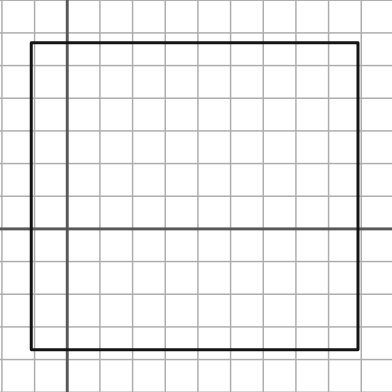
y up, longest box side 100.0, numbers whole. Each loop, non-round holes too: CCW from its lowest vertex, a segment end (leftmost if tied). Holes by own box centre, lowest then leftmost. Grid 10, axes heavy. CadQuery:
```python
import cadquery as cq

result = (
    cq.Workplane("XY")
    .moveTo(-11.0, -37.0)
    .lineTo(89.0, -37.0)
    .lineTo(89.0, 57.0)
    .lineTo(-11.0, 57.0)
    .close()
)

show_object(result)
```